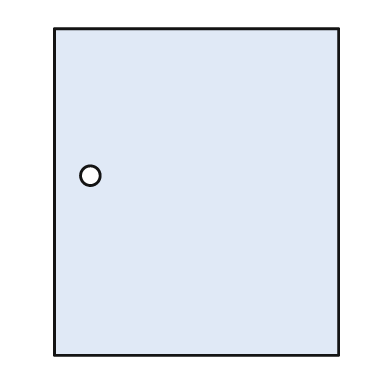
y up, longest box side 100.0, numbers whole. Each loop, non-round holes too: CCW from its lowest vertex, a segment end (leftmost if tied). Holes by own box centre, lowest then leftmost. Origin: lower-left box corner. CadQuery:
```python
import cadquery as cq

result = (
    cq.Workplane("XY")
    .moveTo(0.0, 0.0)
    .lineTo(87.0, 0.0)
    .lineTo(87.0, 100.0)
    .lineTo(0.0, 100.0)
    .close()
    .moveTo(11.0, 55.0)
    .circle(3.0)
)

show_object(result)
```